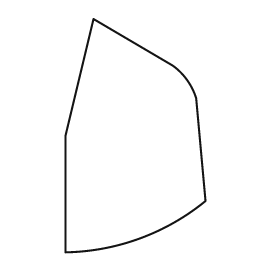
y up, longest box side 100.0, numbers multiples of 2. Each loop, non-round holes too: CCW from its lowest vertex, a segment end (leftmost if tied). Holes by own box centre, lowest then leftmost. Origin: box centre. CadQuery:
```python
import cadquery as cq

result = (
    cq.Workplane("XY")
    .moveTo(-30.0, -50.0)
    .threePointArc((2.0, -44.0), (30.0, -28.0))
    .lineTo(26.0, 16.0)
    .threePointArc((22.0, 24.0), (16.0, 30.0))
    .lineTo(-18.0, 50.0)
    .lineTo(-30.0, 0.0)
    .close()
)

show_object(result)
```